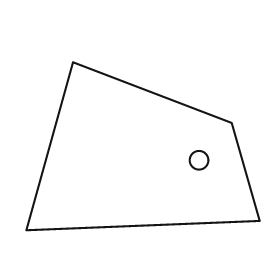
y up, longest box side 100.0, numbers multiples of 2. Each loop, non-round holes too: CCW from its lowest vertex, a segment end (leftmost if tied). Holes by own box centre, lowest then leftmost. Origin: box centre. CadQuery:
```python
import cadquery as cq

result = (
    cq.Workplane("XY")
    .moveTo(-50.0, -36.0)
    .lineTo(50.0, -32.0)
    .lineTo(38.0, 10.0)
    .lineTo(-30.0, 36.0)
    .close()
    .moveTo(24.0, -6.0)
    .circle(4.0)
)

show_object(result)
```